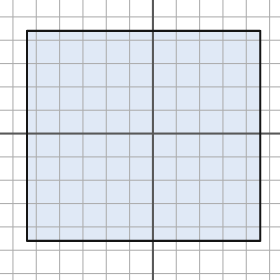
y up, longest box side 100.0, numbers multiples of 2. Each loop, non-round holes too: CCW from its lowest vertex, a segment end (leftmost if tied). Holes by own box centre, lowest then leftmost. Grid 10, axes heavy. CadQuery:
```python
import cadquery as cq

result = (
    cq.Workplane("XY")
    .moveTo(-54.0, -46.0)
    .lineTo(46.0, -46.0)
    .lineTo(46.0, 44.0)
    .lineTo(-54.0, 44.0)
    .close()
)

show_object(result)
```